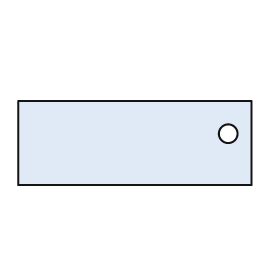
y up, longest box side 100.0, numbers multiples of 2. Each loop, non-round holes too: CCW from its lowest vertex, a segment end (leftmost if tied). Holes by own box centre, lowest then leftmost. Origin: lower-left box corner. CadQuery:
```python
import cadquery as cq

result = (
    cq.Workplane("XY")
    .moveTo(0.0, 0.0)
    .lineTo(100.0, 0.0)
    .lineTo(100.0, 36.0)
    .lineTo(0.0, 36.0)
    .close()
    .moveTo(90.0, 22.0)
    .circle(4.0)
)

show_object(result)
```